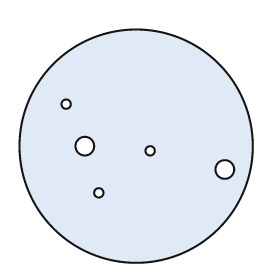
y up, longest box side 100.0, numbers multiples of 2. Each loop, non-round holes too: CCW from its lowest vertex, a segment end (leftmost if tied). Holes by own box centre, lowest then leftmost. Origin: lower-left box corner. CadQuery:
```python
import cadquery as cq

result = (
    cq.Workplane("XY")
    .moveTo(50.0, 50.0)
    .circle(50.0)
    .moveTo(34.0, 30.0)
    .circle(2.0)
    .moveTo(88.0, 40.0)
    .circle(4.0)
    .moveTo(56.0, 48.0)
    .circle(2.0)
    .moveTo(28.0, 50.0)
    .circle(4.0)
    .moveTo(20.0, 68.0)
    .circle(2.0)
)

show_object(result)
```